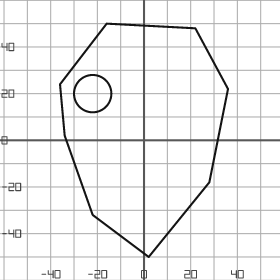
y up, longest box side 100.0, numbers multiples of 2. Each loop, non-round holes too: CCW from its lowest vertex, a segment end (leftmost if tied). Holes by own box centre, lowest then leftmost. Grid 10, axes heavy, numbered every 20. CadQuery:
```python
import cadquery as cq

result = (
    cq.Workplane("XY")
    .moveTo(2.0, -50.0)
    .lineTo(28.0, -18.0)
    .lineTo(36.0, 22.0)
    .lineTo(22.0, 48.0)
    .lineTo(-16.0, 50.0)
    .lineTo(-36.0, 24.0)
    .lineTo(-34.0, 2.0)
    .lineTo(-22.0, -32.0)
    .close()
    .moveTo(-22.0, 20.0)
    .circle(8.0)
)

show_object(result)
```